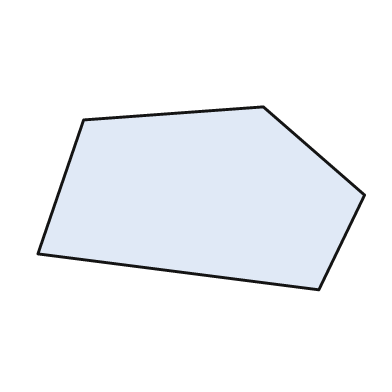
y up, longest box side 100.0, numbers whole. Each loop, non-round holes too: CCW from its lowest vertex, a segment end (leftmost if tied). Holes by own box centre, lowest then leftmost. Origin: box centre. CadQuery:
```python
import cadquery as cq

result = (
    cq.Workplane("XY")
    .moveTo(36.0, -28.0)
    .lineTo(50.0, 1.0)
    .lineTo(19.0, 28.0)
    .lineTo(-36.0, 24.0)
    .lineTo(-50.0, -17.0)
    .close()
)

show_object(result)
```